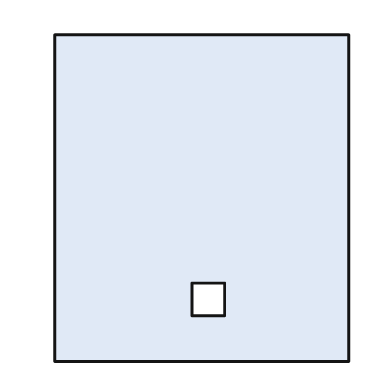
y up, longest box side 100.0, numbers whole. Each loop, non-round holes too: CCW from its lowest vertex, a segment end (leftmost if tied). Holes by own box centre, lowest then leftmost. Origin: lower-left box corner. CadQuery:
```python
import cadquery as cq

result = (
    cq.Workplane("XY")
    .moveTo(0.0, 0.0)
    .lineTo(90.0, 0.0)
    .lineTo(90.0, 100.0)
    .lineTo(0.0, 100.0)
    .close()
    .moveTo(42.0, 14.0)
    .lineTo(52.0, 14.0)
    .lineTo(52.0, 24.0)
    .lineTo(42.0, 24.0)
    .close()
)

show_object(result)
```